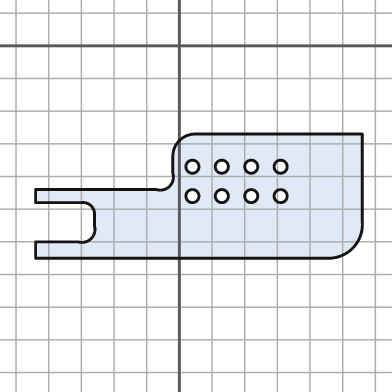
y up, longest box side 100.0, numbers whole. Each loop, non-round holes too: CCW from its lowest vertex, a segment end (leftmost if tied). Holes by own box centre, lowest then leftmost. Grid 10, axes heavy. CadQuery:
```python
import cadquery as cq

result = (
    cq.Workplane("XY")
    .moveTo(-44.0, -65.0)
    .lineTo(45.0, -65.0)
    .threePointArc((53.0, -62.0), (56.0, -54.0))
    .lineTo(56.0, -27.0)
    .lineTo(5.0, -27.0)
    .threePointArc((0.0, -29.0), (-2.0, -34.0))
    .lineTo(-2.0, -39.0)
    .threePointArc((-3.0, -43.0), (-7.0, -44.0))
    .lineTo(-44.0, -44.0)
    .lineTo(-44.0, -48.0)
    .lineTo(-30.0, -48.0)
    .threePointArc((-27.0, -49.0), (-26.0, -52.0))
    .lineTo(-26.0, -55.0)
    .threePointArc((-27.0, -59.0), (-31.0, -60.0))
    .lineTo(-44.0, -60.0)
    .close()
    .moveTo(4.0, -46.0)
    .circle(2.0)
    .moveTo(13.0, -46.0)
    .circle(2.0)
    .moveTo(22.0, -46.0)
    .circle(2.0)
    .moveTo(31.0, -46.0)
    .circle(2.0)
    .moveTo(4.0, -37.0)
    .circle(2.0)
    .moveTo(13.0, -37.0)
    .circle(2.0)
    .moveTo(22.0, -37.0)
    .circle(2.0)
    .moveTo(31.0, -37.0)
    .circle(2.0)
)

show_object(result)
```